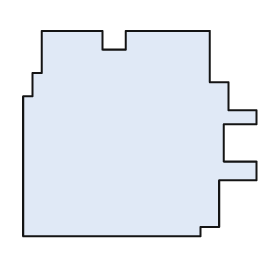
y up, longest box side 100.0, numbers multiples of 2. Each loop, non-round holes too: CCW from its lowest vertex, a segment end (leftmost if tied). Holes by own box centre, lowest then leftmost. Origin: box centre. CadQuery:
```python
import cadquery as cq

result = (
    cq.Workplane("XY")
    .moveTo(-50.0, -44.0)
    .lineTo(26.0, -44.0)
    .lineTo(26.0, -40.0)
    .lineTo(34.0, -40.0)
    .lineTo(34.0, -20.0)
    .lineTo(50.0, -20.0)
    .lineTo(50.0, -12.0)
    .lineTo(36.0, -12.0)
    .lineTo(36.0, 4.0)
    .lineTo(50.0, 4.0)
    .lineTo(50.0, 10.0)
    .lineTo(38.0, 10.0)
    .lineTo(38.0, 22.0)
    .lineTo(30.0, 22.0)
    .lineTo(30.0, 44.0)
    .lineTo(-6.0, 44.0)
    .lineTo(-6.0, 36.0)
    .lineTo(-16.0, 36.0)
    .lineTo(-16.0, 44.0)
    .lineTo(-42.0, 44.0)
    .lineTo(-42.0, 26.0)
    .lineTo(-46.0, 26.0)
    .lineTo(-46.0, 16.0)
    .lineTo(-50.0, 16.0)
    .close()
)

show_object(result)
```